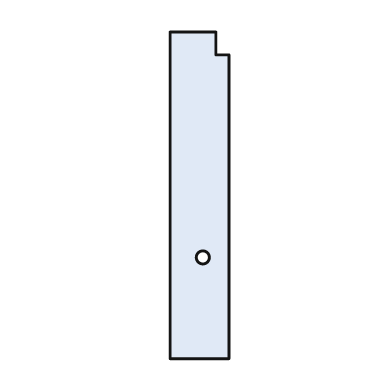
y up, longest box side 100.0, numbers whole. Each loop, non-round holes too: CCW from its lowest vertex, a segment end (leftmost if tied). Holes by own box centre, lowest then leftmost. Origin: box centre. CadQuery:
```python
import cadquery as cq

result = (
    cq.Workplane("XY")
    .moveTo(-9.0, -50.0)
    .lineTo(9.0, -50.0)
    .lineTo(9.0, 43.0)
    .lineTo(5.0, 43.0)
    .lineTo(5.0, 50.0)
    .lineTo(-9.0, 50.0)
    .close()
    .moveTo(1.0, -19.0)
    .circle(2.0)
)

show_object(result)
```